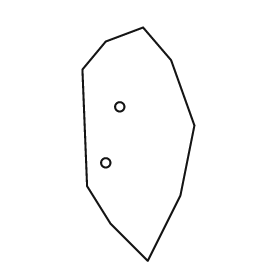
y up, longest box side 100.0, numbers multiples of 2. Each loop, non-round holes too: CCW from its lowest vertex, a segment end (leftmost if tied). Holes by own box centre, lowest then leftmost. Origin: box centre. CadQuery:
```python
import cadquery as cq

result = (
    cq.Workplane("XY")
    .moveTo(4.0, -50.0)
    .lineTo(18.0, -22.0)
    .lineTo(24.0, 8.0)
    .lineTo(14.0, 36.0)
    .lineTo(2.0, 50.0)
    .lineTo(-14.0, 44.0)
    .lineTo(-24.0, 32.0)
    .lineTo(-22.0, -18.0)
    .lineTo(-12.0, -34.0)
    .close()
    .moveTo(-14.0, -8.0)
    .circle(2.0)
    .moveTo(-8.0, 16.0)
    .circle(2.0)
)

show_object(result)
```